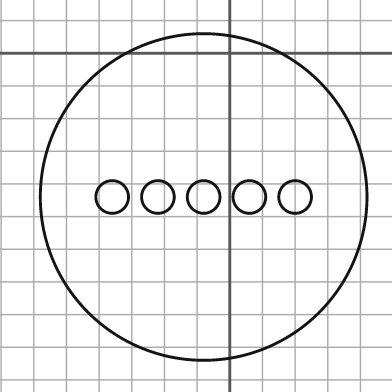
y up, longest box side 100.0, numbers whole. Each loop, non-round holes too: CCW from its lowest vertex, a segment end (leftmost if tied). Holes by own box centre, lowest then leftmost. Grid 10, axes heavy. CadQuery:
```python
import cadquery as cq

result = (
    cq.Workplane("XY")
    .moveTo(-8.0, -44.0)
    .circle(50.0)
    .moveTo(-36.0, -44.0)
    .circle(5.0)
    .moveTo(-22.0, -44.0)
    .circle(5.0)
    .moveTo(-8.0, -44.0)
    .circle(5.0)
    .moveTo(6.0, -44.0)
    .circle(5.0)
    .moveTo(20.0, -44.0)
    .circle(5.0)
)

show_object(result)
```